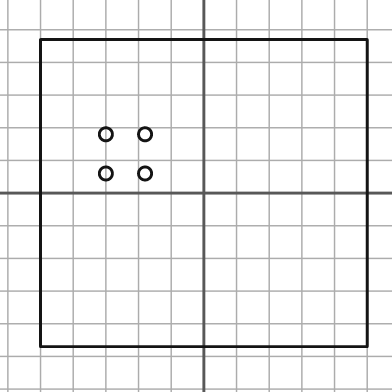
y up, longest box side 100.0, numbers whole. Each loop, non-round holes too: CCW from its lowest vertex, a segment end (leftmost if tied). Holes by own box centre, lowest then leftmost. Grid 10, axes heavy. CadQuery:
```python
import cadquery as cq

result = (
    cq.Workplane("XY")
    .moveTo(-50.0, -47.0)
    .lineTo(50.0, -47.0)
    .lineTo(50.0, 47.0)
    .lineTo(-50.0, 47.0)
    .close()
    .moveTo(-30.0, 6.0)
    .circle(2.0)
    .moveTo(-18.0, 6.0)
    .circle(2.0)
    .moveTo(-30.0, 18.0)
    .circle(2.0)
    .moveTo(-18.0, 18.0)
    .circle(2.0)
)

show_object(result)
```